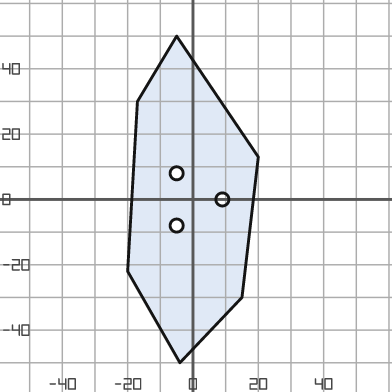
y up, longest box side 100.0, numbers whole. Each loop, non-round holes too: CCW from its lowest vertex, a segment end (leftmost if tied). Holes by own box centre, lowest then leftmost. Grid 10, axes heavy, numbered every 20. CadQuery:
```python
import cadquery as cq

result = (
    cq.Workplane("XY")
    .moveTo(-4.0, -50.0)
    .lineTo(15.0, -30.0)
    .lineTo(20.0, 13.0)
    .lineTo(-5.0, 50.0)
    .lineTo(-17.0, 30.0)
    .lineTo(-20.0, -22.0)
    .close()
    .moveTo(-5.0, -8.0)
    .circle(2.0)
    .moveTo(9.0, 0.0)
    .circle(2.0)
    .moveTo(-5.0, 8.0)
    .circle(2.0)
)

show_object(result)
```